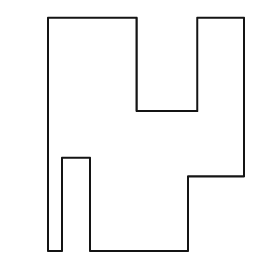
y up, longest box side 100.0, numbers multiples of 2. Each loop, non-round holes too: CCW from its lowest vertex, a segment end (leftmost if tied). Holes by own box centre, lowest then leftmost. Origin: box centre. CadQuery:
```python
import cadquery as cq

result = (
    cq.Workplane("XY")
    .moveTo(-42.0, -50.0)
    .lineTo(-36.0, -50.0)
    .lineTo(-36.0, -10.0)
    .lineTo(-24.0, -10.0)
    .lineTo(-24.0, -50.0)
    .lineTo(18.0, -50.0)
    .lineTo(18.0, -18.0)
    .lineTo(42.0, -18.0)
    .lineTo(42.0, 50.0)
    .lineTo(22.0, 50.0)
    .lineTo(22.0, 10.0)
    .lineTo(-4.0, 10.0)
    .lineTo(-4.0, 50.0)
    .lineTo(-42.0, 50.0)
    .close()
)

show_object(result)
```